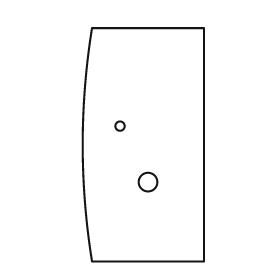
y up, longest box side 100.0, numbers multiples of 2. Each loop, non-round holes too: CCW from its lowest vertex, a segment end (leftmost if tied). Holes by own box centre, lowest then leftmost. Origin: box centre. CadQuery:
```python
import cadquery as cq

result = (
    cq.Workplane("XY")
    .moveTo(-22.0, -50.0)
    .lineTo(26.0, -50.0)
    .lineTo(26.0, 50.0)
    .lineTo(-22.0, 50.0)
    .threePointArc((-26.0, 0.0), (-22.0, -50.0))
    .close()
    .moveTo(2.0, -16.0)
    .circle(4.0)
    .moveTo(-10.0, 8.0)
    .circle(2.0)
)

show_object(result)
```